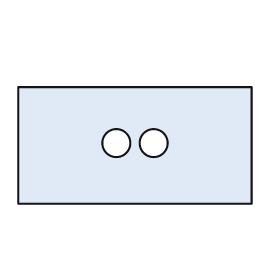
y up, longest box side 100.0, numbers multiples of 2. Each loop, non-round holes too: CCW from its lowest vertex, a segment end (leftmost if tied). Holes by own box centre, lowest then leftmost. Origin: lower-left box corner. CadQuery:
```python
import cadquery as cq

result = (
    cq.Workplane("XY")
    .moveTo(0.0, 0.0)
    .lineTo(100.0, 0.0)
    .lineTo(100.0, 50.0)
    .lineTo(0.0, 50.0)
    .close()
    .moveTo(42.0, 26.0)
    .circle(6.0)
    .moveTo(58.0, 26.0)
    .circle(6.0)
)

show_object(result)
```